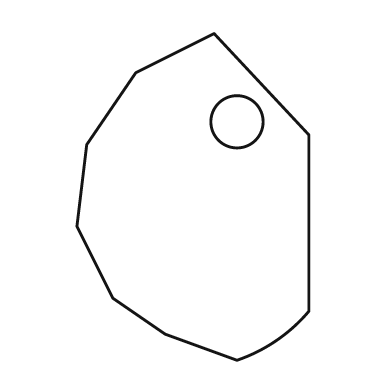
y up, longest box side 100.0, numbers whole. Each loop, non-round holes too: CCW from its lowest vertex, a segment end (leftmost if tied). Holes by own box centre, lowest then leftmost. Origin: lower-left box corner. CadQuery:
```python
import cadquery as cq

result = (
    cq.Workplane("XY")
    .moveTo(49.0, 0.0)
    .threePointArc((61.0, 6.0), (71.0, 15.0))
    .lineTo(71.0, 69.0)
    .lineTo(42.0, 100.0)
    .lineTo(18.0, 88.0)
    .lineTo(3.0, 66.0)
    .lineTo(0.0, 41.0)
    .lineTo(11.0, 19.0)
    .lineTo(27.0, 8.0)
    .close()
    .moveTo(49.0, 73.0)
    .circle(8.0)
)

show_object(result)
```